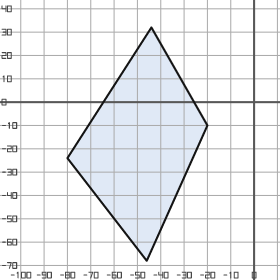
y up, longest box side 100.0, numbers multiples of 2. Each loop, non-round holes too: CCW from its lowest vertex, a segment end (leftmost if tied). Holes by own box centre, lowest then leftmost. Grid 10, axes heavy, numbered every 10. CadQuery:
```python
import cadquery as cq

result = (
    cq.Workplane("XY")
    .moveTo(-46.0, -68.0)
    .lineTo(-20.0, -10.0)
    .lineTo(-44.0, 32.0)
    .lineTo(-80.0, -24.0)
    .close()
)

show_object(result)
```